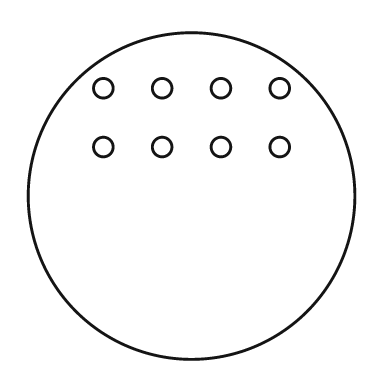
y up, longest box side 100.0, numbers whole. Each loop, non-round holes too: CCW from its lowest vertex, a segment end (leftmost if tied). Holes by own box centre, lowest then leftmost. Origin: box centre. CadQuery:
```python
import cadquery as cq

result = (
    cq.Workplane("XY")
    .moveTo(0.0, 0.0)
    .circle(50.0)
    .moveTo(-27.0, 15.0)
    .circle(3.0)
    .moveTo(-9.0, 15.0)
    .circle(3.0)
    .moveTo(9.0, 15.0)
    .circle(3.0)
    .moveTo(27.0, 15.0)
    .circle(3.0)
    .moveTo(-27.0, 33.0)
    .circle(3.0)
    .moveTo(-9.0, 33.0)
    .circle(3.0)
    .moveTo(9.0, 33.0)
    .circle(3.0)
    .moveTo(27.0, 33.0)
    .circle(3.0)
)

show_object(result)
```